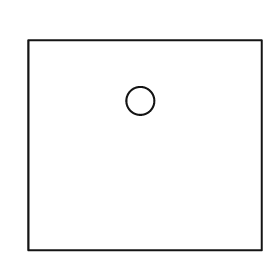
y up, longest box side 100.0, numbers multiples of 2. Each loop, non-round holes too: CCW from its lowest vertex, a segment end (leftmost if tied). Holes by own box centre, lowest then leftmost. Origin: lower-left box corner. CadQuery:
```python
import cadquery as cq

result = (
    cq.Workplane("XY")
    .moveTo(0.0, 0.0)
    .lineTo(100.0, 0.0)
    .lineTo(100.0, 90.0)
    .lineTo(0.0, 90.0)
    .close()
    .moveTo(48.0, 64.0)
    .circle(6.0)
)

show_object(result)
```